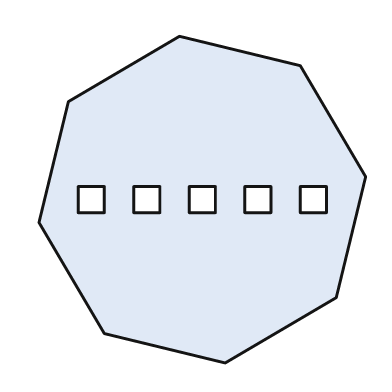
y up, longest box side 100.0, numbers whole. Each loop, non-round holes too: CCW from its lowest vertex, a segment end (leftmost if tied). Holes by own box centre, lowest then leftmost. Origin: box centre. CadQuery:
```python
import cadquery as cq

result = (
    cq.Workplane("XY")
    .moveTo(7.0, -50.0)
    .lineTo(41.0, -30.0)
    .lineTo(50.0, 7.0)
    .lineTo(30.0, 41.0)
    .lineTo(-7.0, 50.0)
    .lineTo(-41.0, 30.0)
    .lineTo(-50.0, -7.0)
    .lineTo(-30.0, -41.0)
    .close()
    .moveTo(-38.0, -4.0)
    .lineTo(-30.0, -4.0)
    .lineTo(-30.0, 4.0)
    .lineTo(-38.0, 4.0)
    .close()
    .moveTo(-21.0, -4.0)
    .lineTo(-13.0, -4.0)
    .lineTo(-13.0, 4.0)
    .lineTo(-21.0, 4.0)
    .close()
    .moveTo(-4.0, -4.0)
    .lineTo(4.0, -4.0)
    .lineTo(4.0, 4.0)
    .lineTo(-4.0, 4.0)
    .close()
    .moveTo(13.0, -4.0)
    .lineTo(21.0, -4.0)
    .lineTo(21.0, 4.0)
    .lineTo(13.0, 4.0)
    .close()
    .moveTo(30.0, -4.0)
    .lineTo(38.0, -4.0)
    .lineTo(38.0, 4.0)
    .lineTo(30.0, 4.0)
    .close()
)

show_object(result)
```